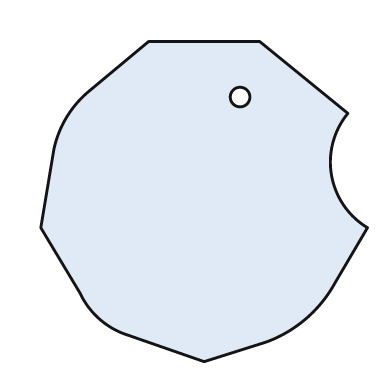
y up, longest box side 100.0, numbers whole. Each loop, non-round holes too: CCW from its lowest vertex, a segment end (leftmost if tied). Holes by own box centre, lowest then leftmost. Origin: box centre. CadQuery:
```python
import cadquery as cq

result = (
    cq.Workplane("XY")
    .moveTo(0.0, -49.0)
    .lineTo(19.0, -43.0)
    .threePointArc((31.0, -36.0), (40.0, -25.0))
    .lineTo(50.0, -8.0)
    .threePointArc((39.0, 8.0), (44.0, 27.0))
    .lineTo(17.0, 49.0)
    .lineTo(-17.0, 49.0)
    .lineTo(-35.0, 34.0)
    .threePointArc((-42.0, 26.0), (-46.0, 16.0))
    .lineTo(-50.0, -8.0)
    .lineTo(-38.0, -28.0)
    .threePointArc((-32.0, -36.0), (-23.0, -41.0))
    .close()
    .moveTo(11.0, 32.0)
    .circle(3.0)
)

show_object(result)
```